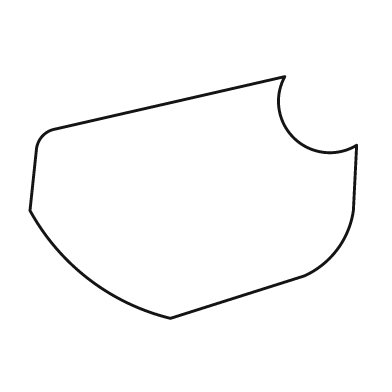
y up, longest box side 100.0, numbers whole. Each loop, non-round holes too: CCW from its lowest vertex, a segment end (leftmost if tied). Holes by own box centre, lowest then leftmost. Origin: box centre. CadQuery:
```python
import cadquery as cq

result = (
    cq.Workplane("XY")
    .moveTo(-7.0, -37.0)
    .lineTo(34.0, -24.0)
    .threePointArc((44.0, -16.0), (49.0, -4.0))
    .lineTo(50.0, 16.0)
    .threePointArc((31.0, 18.0), (28.0, 37.0))
    .lineTo(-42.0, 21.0)
    .threePointArc((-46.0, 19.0), (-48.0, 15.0))
    .lineTo(-50.0, -4.0)
    .threePointArc((-32.0, -25.0), (-7.0, -37.0))
    .close()
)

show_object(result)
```